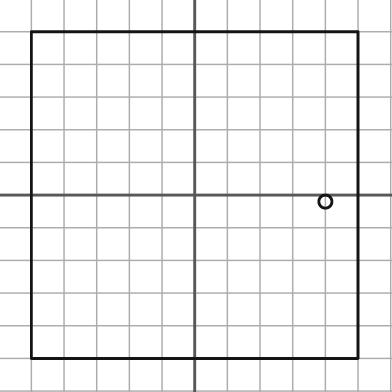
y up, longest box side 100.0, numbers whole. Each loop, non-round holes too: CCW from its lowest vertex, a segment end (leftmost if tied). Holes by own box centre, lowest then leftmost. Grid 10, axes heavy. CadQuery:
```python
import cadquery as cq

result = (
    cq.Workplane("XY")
    .moveTo(-50.0, -50.0)
    .lineTo(50.0, -50.0)
    .lineTo(50.0, 50.0)
    .lineTo(-50.0, 50.0)
    .close()
    .moveTo(40.0, -2.0)
    .circle(2.0)
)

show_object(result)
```